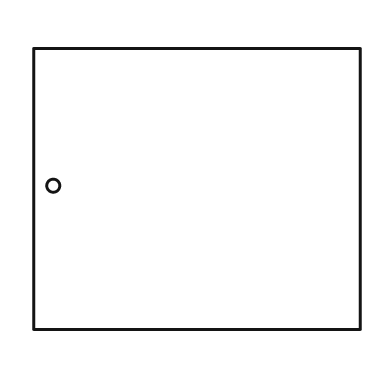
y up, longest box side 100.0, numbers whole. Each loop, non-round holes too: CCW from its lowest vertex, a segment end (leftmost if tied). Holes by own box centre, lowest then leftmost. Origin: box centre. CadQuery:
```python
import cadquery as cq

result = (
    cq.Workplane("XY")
    .moveTo(-50.0, -43.0)
    .lineTo(50.0, -43.0)
    .lineTo(50.0, 43.0)
    .lineTo(-50.0, 43.0)
    .close()
    .moveTo(-44.0, 1.0)
    .circle(2.0)
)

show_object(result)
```